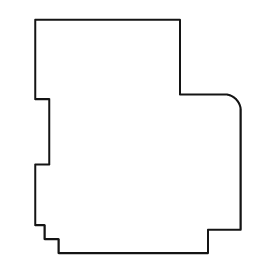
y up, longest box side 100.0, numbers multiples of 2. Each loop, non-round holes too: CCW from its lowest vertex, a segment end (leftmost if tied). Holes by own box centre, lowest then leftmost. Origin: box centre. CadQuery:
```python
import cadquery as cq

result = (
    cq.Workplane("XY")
    .moveTo(-34.0, -50.0)
    .lineTo(30.0, -50.0)
    .lineTo(30.0, -40.0)
    .lineTo(44.0, -40.0)
    .lineTo(44.0, 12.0)
    .threePointArc((42.0, 16.0), (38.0, 18.0))
    .lineTo(18.0, 18.0)
    .lineTo(18.0, 50.0)
    .lineTo(-44.0, 50.0)
    .lineTo(-44.0, 16.0)
    .lineTo(-38.0, 16.0)
    .lineTo(-38.0, -12.0)
    .lineTo(-44.0, -12.0)
    .lineTo(-44.0, -38.0)
    .lineTo(-40.0, -38.0)
    .lineTo(-40.0, -44.0)
    .lineTo(-34.0, -44.0)
    .close()
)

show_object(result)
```